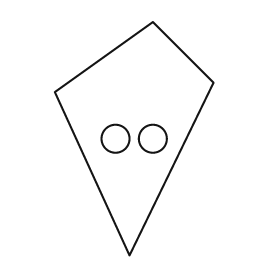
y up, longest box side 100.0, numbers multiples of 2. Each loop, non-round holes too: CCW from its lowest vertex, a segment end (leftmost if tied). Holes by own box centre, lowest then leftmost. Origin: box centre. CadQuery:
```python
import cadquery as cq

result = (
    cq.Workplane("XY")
    .moveTo(-2.0, -50.0)
    .lineTo(34.0, 24.0)
    .lineTo(8.0, 50.0)
    .lineTo(-34.0, 20.0)
    .close()
    .moveTo(-8.0, 0.0)
    .circle(6.0)
    .moveTo(8.0, 0.0)
    .circle(6.0)
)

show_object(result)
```